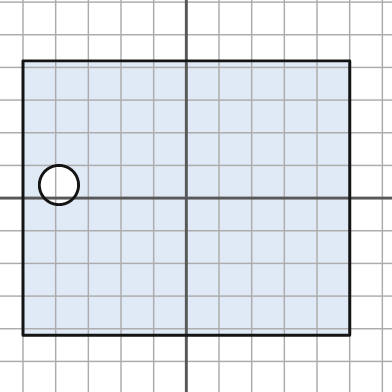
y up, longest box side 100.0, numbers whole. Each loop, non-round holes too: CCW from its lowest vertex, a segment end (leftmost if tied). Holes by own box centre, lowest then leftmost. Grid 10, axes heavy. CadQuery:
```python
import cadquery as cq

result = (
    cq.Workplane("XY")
    .moveTo(-50.0, -42.0)
    .lineTo(50.0, -42.0)
    .lineTo(50.0, 42.0)
    .lineTo(-50.0, 42.0)
    .close()
    .moveTo(-39.0, 4.0)
    .circle(6.0)
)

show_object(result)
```